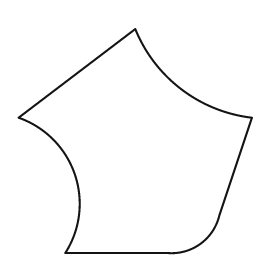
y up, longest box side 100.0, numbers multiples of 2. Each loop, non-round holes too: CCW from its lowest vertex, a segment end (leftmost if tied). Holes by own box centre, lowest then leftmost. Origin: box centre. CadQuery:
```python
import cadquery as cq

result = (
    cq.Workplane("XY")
    .moveTo(-30.0, -48.0)
    .lineTo(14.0, -48.0)
    .threePointArc((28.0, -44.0), (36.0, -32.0))
    .lineTo(50.0, 10.0)
    .threePointArc((20.0, 22.0), (0.0, 48.0))
    .lineTo(-50.0, 10.0)
    .threePointArc((-26.0, -14.0), (-30.0, -48.0))
    .close()
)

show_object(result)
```